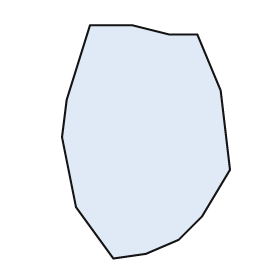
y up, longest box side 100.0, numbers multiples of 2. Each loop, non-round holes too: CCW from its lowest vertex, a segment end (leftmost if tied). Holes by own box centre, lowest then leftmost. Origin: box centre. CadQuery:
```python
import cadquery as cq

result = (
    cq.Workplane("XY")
    .moveTo(-14.0, -50.0)
    .lineTo(0.0, -48.0)
    .lineTo(14.0, -42.0)
    .lineTo(24.0, -32.0)
    .lineTo(36.0, -12.0)
    .lineTo(32.0, 22.0)
    .lineTo(22.0, 46.0)
    .lineTo(10.0, 46.0)
    .lineTo(-6.0, 50.0)
    .lineTo(-24.0, 50.0)
    .lineTo(-34.0, 18.0)
    .lineTo(-36.0, 2.0)
    .lineTo(-30.0, -28.0)
    .close()
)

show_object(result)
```